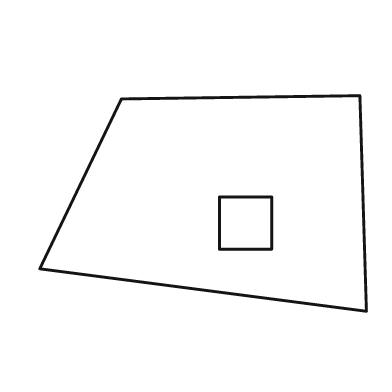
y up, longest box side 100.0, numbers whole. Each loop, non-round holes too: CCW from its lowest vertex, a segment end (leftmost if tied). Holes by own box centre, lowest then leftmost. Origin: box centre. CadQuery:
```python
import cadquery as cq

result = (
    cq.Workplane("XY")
    .moveTo(50.0, -33.0)
    .lineTo(48.0, 33.0)
    .lineTo(-25.0, 32.0)
    .lineTo(-50.0, -20.0)
    .close()
    .moveTo(5.0, -14.0)
    .lineTo(21.0, -14.0)
    .lineTo(21.0, 2.0)
    .lineTo(5.0, 2.0)
    .close()
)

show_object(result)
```